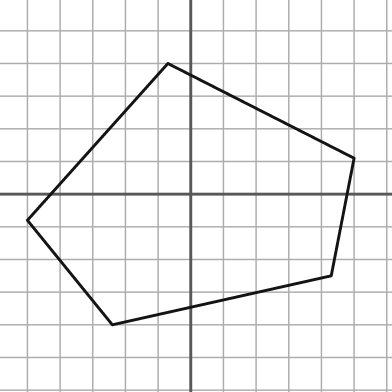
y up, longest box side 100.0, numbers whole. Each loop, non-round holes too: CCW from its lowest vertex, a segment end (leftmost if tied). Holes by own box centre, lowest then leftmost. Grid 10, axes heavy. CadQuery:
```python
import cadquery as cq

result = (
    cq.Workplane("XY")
    .moveTo(-24.0, -40.0)
    .lineTo(43.0, -25.0)
    .lineTo(50.0, 11.0)
    .lineTo(-7.0, 40.0)
    .lineTo(-50.0, -8.0)
    .close()
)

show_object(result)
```